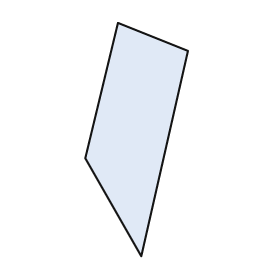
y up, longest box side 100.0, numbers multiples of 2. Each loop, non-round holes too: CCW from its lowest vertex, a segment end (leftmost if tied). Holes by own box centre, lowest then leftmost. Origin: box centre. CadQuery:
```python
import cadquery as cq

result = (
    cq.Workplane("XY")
    .moveTo(2.0, -50.0)
    .lineTo(22.0, 38.0)
    .lineTo(-8.0, 50.0)
    .lineTo(-22.0, -8.0)
    .close()
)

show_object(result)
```